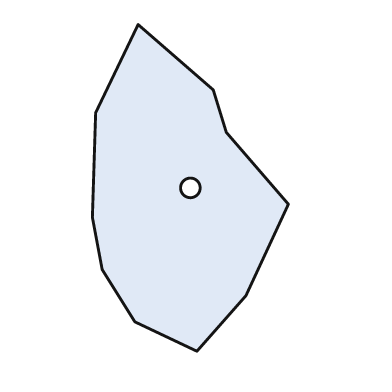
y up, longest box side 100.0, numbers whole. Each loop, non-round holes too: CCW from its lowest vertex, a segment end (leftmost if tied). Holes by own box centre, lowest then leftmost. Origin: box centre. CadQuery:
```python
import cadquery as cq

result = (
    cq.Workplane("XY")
    .moveTo(2.0, -50.0)
    .lineTo(17.0, -33.0)
    .lineTo(30.0, -5.0)
    .lineTo(11.0, 17.0)
    .lineTo(7.0, 30.0)
    .lineTo(-16.0, 50.0)
    .lineTo(-29.0, 23.0)
    .lineTo(-30.0, -9.0)
    .lineTo(-27.0, -25.0)
    .lineTo(-17.0, -41.0)
    .close()
    .moveTo(0.0, 0.0)
    .circle(3.0)
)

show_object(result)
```